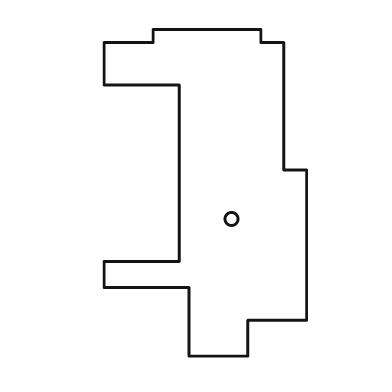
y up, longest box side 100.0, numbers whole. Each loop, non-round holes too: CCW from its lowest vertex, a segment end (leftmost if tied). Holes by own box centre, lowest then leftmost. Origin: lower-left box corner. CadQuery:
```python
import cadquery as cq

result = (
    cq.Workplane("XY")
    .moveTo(26.0, 0.0)
    .lineTo(44.0, 0.0)
    .lineTo(44.0, 11.0)
    .lineTo(62.0, 11.0)
    .lineTo(62.0, 57.0)
    .lineTo(55.0, 57.0)
    .lineTo(55.0, 96.0)
    .lineTo(48.0, 96.0)
    .lineTo(48.0, 100.0)
    .lineTo(15.0, 100.0)
    .lineTo(15.0, 96.0)
    .lineTo(0.0, 96.0)
    .lineTo(0.0, 83.0)
    .lineTo(23.0, 83.0)
    .lineTo(23.0, 29.0)
    .lineTo(0.0, 29.0)
    .lineTo(0.0, 21.0)
    .lineTo(26.0, 21.0)
    .close()
    .moveTo(39.0, 42.0)
    .circle(2.0)
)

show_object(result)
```